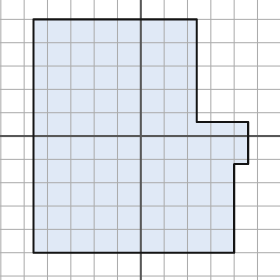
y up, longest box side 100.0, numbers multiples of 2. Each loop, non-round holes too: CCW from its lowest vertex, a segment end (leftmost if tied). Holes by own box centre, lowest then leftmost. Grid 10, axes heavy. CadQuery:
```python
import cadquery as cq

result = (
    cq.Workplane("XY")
    .moveTo(-46.0, -50.0)
    .lineTo(40.0, -50.0)
    .lineTo(40.0, -12.0)
    .lineTo(46.0, -12.0)
    .lineTo(46.0, 6.0)
    .lineTo(24.0, 6.0)
    .lineTo(24.0, 50.0)
    .lineTo(-46.0, 50.0)
    .close()
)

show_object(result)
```